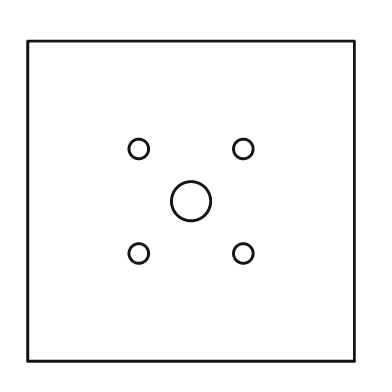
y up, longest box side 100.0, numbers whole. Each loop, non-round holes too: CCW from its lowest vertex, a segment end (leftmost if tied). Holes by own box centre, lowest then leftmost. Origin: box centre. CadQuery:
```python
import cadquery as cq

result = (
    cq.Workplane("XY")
    .moveTo(-50.0, -49.0)
    .lineTo(50.0, -49.0)
    .lineTo(50.0, 49.0)
    .lineTo(-50.0, 49.0)
    .close()
    .moveTo(-16.0, -16.0)
    .circle(3.0)
    .moveTo(16.0, -16.0)
    .circle(3.0)
    .moveTo(0.0, 0.0)
    .circle(6.0)
    .moveTo(-16.0, 16.0)
    .circle(3.0)
    .moveTo(16.0, 16.0)
    .circle(3.0)
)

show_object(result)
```